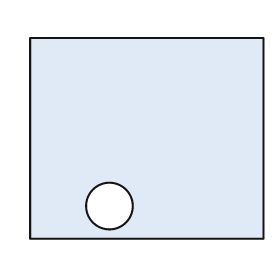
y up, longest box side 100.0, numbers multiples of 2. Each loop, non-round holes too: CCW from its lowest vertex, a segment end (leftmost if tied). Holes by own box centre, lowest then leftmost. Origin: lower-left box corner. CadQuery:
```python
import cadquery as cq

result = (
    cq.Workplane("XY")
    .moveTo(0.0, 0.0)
    .lineTo(100.0, 0.0)
    .lineTo(100.0, 86.0)
    .lineTo(0.0, 86.0)
    .close()
    .moveTo(34.0, 14.0)
    .circle(10.0)
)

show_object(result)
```